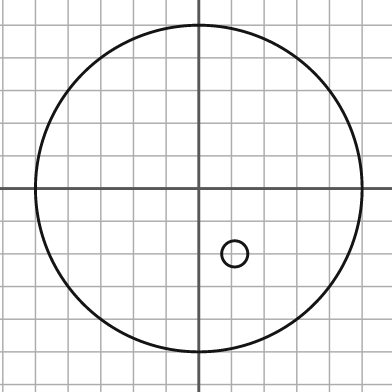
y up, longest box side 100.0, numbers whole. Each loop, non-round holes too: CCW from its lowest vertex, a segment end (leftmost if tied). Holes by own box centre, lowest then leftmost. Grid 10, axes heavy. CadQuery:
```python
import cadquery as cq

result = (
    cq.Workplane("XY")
    .moveTo(0.0, 0.0)
    .circle(50.0)
    .moveTo(11.0, -20.0)
    .circle(4.0)
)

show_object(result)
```